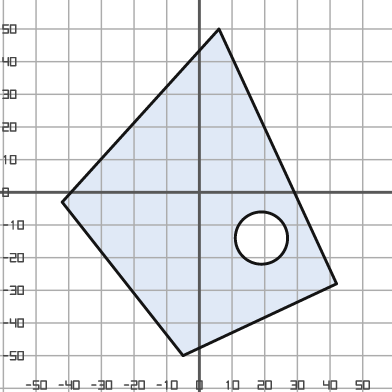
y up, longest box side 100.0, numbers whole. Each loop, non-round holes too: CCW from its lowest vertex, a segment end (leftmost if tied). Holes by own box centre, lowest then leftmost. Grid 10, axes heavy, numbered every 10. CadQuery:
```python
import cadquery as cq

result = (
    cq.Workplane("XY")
    .moveTo(-5.0, -50.0)
    .lineTo(42.0, -28.0)
    .lineTo(6.0, 50.0)
    .lineTo(-42.0, -3.0)
    .close()
    .moveTo(19.0, -14.0)
    .circle(8.0)
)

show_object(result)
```